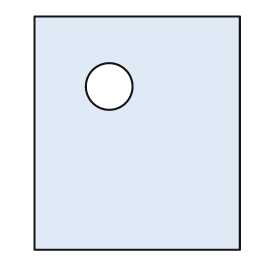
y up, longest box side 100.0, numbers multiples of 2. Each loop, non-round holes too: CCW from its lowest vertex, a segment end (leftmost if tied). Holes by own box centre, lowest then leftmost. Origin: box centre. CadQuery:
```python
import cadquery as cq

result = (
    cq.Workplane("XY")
    .moveTo(-44.0, -50.0)
    .lineTo(44.0, -50.0)
    .lineTo(44.0, 50.0)
    .lineTo(-44.0, 50.0)
    .close()
    .moveTo(-12.0, 20.0)
    .circle(10.0)
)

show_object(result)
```